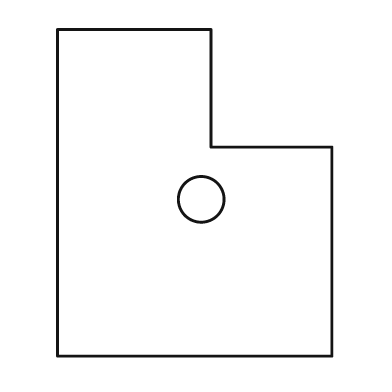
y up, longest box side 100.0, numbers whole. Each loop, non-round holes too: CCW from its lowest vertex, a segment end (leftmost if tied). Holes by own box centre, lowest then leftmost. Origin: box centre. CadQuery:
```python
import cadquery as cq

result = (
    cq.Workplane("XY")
    .moveTo(-42.0, -50.0)
    .lineTo(42.0, -50.0)
    .lineTo(42.0, 14.0)
    .lineTo(5.0, 14.0)
    .lineTo(5.0, 50.0)
    .lineTo(-42.0, 50.0)
    .close()
    .moveTo(2.0, -2.0)
    .circle(7.0)
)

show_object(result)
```